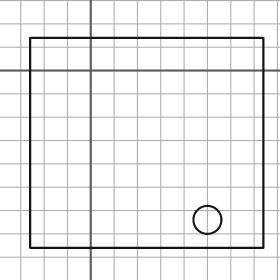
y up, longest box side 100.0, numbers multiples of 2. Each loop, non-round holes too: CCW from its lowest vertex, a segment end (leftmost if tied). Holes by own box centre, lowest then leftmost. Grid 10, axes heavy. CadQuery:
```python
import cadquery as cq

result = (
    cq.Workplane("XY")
    .moveTo(-26.0, -76.0)
    .lineTo(74.0, -76.0)
    .lineTo(74.0, 14.0)
    .lineTo(-26.0, 14.0)
    .close()
    .moveTo(50.0, -64.0)
    .circle(6.0)
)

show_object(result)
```